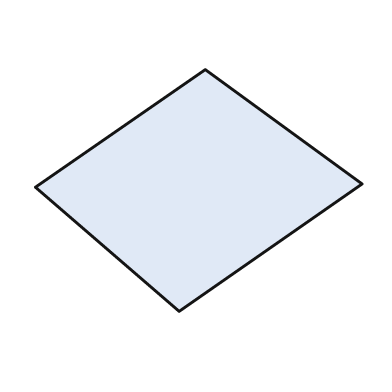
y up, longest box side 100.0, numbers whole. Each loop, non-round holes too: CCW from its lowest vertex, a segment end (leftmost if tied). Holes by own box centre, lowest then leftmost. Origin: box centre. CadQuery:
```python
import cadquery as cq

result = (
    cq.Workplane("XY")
    .moveTo(-6.0, -37.0)
    .lineTo(50.0, 2.0)
    .lineTo(2.0, 37.0)
    .lineTo(-50.0, 1.0)
    .close()
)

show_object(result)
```